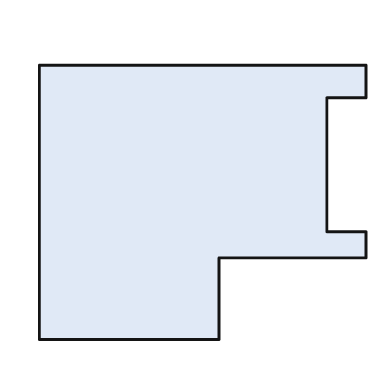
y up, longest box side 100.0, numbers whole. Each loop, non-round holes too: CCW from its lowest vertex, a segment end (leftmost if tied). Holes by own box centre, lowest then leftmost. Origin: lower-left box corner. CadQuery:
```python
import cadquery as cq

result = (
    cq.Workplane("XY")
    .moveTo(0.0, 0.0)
    .lineTo(55.0, 0.0)
    .lineTo(55.0, 25.0)
    .lineTo(100.0, 25.0)
    .lineTo(100.0, 33.0)
    .lineTo(88.0, 33.0)
    .lineTo(88.0, 74.0)
    .lineTo(100.0, 74.0)
    .lineTo(100.0, 84.0)
    .lineTo(0.0, 84.0)
    .close()
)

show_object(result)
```